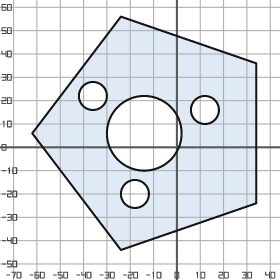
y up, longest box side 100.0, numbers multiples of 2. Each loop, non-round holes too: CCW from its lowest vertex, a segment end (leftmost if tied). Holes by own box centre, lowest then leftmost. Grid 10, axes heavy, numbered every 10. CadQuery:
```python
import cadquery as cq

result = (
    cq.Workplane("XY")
    .moveTo(-24.0, -44.0)
    .lineTo(34.0, -24.0)
    .lineTo(34.0, 36.0)
    .lineTo(-24.0, 56.0)
    .lineTo(-62.0, 6.0)
    .close()
    .moveTo(-18.0, -20.0)
    .circle(6.0)
    .moveTo(-14.0, 6.0)
    .circle(16.0)
    .moveTo(12.0, 16.0)
    .circle(6.0)
    .moveTo(-36.0, 22.0)
    .circle(6.0)
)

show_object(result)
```